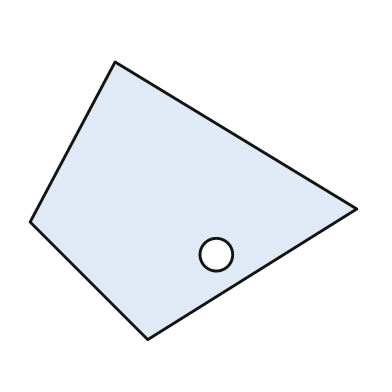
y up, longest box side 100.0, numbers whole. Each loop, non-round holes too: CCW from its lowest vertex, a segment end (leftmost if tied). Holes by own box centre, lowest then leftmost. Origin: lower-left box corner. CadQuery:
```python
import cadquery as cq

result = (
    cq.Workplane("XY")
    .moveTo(36.0, 0.0)
    .lineTo(100.0, 40.0)
    .lineTo(26.0, 85.0)
    .lineTo(0.0, 36.0)
    .close()
    .moveTo(57.0, 26.0)
    .circle(5.0)
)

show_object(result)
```